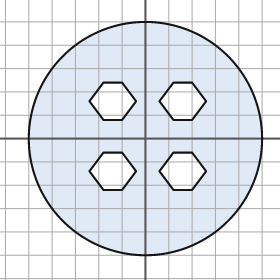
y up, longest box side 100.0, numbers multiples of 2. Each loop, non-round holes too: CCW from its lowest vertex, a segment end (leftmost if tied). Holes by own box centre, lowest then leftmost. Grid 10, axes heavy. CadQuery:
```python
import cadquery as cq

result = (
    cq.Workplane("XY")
    .moveTo(0.0, 0.0)
    .circle(50.0)
    .moveTo(-18.0, -22.0)
    .lineTo(-10.0, -22.0)
    .lineTo(-4.0, -14.0)
    .lineTo(-10.0, -6.0)
    .lineTo(-18.0, -6.0)
    .lineTo(-24.0, -14.0)
    .close()
    .moveTo(12.0, -22.0)
    .lineTo(20.0, -22.0)
    .lineTo(26.0, -14.0)
    .lineTo(20.0, -6.0)
    .lineTo(12.0, -6.0)
    .lineTo(6.0, -14.0)
    .close()
    .moveTo(-18.0, 8.0)
    .lineTo(-10.0, 8.0)
    .lineTo(-4.0, 16.0)
    .lineTo(-10.0, 24.0)
    .lineTo(-18.0, 24.0)
    .lineTo(-24.0, 16.0)
    .close()
    .moveTo(12.0, 8.0)
    .lineTo(20.0, 8.0)
    .lineTo(26.0, 16.0)
    .lineTo(20.0, 24.0)
    .lineTo(12.0, 24.0)
    .lineTo(6.0, 16.0)
    .close()
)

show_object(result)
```